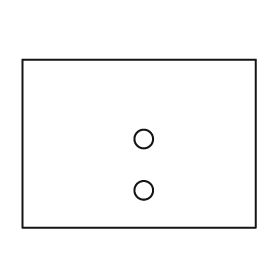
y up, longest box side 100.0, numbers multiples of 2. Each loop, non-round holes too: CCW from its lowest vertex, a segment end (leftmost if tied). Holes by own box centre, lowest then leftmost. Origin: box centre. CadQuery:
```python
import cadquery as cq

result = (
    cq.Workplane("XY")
    .moveTo(-50.0, -36.0)
    .lineTo(50.0, -36.0)
    .lineTo(50.0, 36.0)
    .lineTo(-50.0, 36.0)
    .close()
    .moveTo(2.0, -20.0)
    .circle(4.0)
    .moveTo(2.0, 2.0)
    .circle(4.0)
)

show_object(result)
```